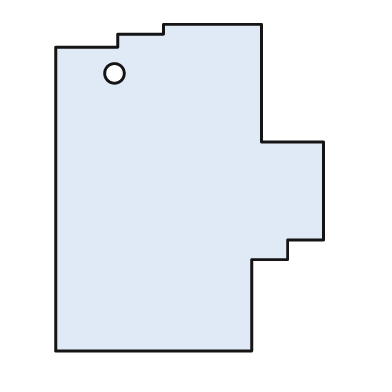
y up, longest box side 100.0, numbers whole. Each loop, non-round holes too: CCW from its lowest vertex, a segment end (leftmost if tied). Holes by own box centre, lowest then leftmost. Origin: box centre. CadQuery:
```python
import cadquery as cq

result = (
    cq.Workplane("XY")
    .moveTo(-41.0, -50.0)
    .lineTo(19.0, -50.0)
    .lineTo(19.0, -22.0)
    .lineTo(30.0, -22.0)
    .lineTo(30.0, -16.0)
    .lineTo(41.0, -16.0)
    .lineTo(41.0, 14.0)
    .lineTo(22.0, 14.0)
    .lineTo(22.0, 50.0)
    .lineTo(-8.0, 50.0)
    .lineTo(-8.0, 47.0)
    .lineTo(-22.0, 47.0)
    .lineTo(-22.0, 43.0)
    .lineTo(-41.0, 43.0)
    .close()
    .moveTo(-23.0, 35.0)
    .circle(3.0)
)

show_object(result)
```